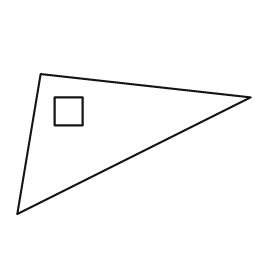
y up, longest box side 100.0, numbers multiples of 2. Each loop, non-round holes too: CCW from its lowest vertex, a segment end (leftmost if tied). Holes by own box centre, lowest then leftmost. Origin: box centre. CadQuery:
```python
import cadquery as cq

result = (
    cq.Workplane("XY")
    .moveTo(-50.0, -30.0)
    .lineTo(50.0, 20.0)
    .lineTo(-40.0, 30.0)
    .close()
    .moveTo(-34.0, 8.0)
    .lineTo(-22.0, 8.0)
    .lineTo(-22.0, 20.0)
    .lineTo(-34.0, 20.0)
    .close()
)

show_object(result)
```